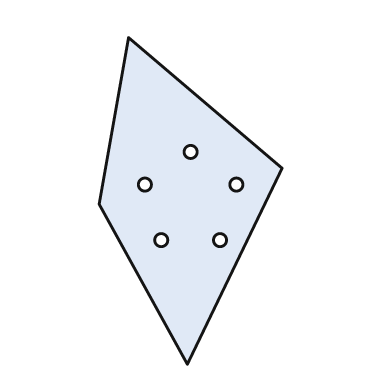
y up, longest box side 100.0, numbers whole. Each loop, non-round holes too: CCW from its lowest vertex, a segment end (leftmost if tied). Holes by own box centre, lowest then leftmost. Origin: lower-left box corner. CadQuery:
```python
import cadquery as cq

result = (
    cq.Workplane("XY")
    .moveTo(27.0, 0.0)
    .lineTo(56.0, 60.0)
    .lineTo(9.0, 100.0)
    .lineTo(0.0, 49.0)
    .close()
    .moveTo(19.0, 38.0)
    .circle(2.0)
    .moveTo(37.0, 38.0)
    .circle(2.0)
    .moveTo(14.0, 55.0)
    .circle(2.0)
    .moveTo(42.0, 55.0)
    .circle(2.0)
    .moveTo(28.0, 65.0)
    .circle(2.0)
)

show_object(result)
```